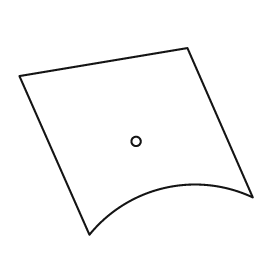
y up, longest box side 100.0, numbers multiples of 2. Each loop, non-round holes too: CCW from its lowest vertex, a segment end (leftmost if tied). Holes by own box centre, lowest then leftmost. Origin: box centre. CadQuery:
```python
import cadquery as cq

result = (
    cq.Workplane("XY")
    .moveTo(-20.0, -40.0)
    .threePointArc((12.0, -20.0), (50.0, -24.0))
    .lineTo(22.0, 40.0)
    .lineTo(-50.0, 28.0)
    .close()
    .moveTo(0.0, 0.0)
    .circle(2.0)
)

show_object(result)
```